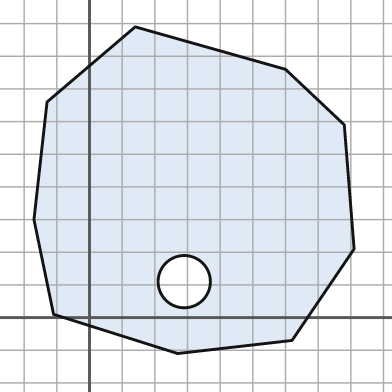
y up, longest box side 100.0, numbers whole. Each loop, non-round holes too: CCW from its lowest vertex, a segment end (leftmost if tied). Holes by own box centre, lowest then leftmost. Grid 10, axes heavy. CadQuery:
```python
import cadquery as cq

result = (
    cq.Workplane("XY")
    .moveTo(27.0, -11.0)
    .lineTo(62.0, -7.0)
    .lineTo(81.0, 21.0)
    .lineTo(78.0, 59.0)
    .lineTo(60.0, 76.0)
    .lineTo(14.0, 89.0)
    .lineTo(-13.0, 66.0)
    .lineTo(-17.0, 30.0)
    .lineTo(-11.0, 1.0)
    .close()
    .moveTo(29.0, 11.0)
    .circle(8.0)
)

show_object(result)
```